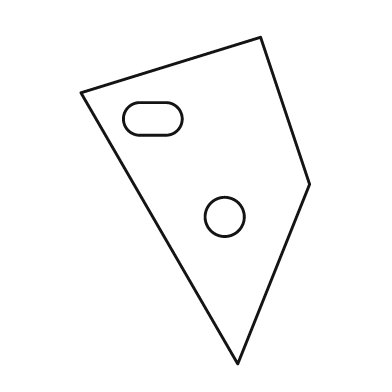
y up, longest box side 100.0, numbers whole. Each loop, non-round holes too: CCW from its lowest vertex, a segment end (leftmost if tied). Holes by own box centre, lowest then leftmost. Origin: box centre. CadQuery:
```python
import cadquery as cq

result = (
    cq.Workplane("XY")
    .moveTo(13.0, -50.0)
    .lineTo(35.0, 5.0)
    .lineTo(20.0, 50.0)
    .lineTo(-35.0, 33.0)
    .close()
    .moveTo(9.0, -5.0)
    .circle(6.0)
    .moveTo(-17.0, 20.0)
    .lineTo(-9.0, 20.0)
    .threePointArc((-4.0, 25.0), (-9.0, 30.0))
    .lineTo(-17.0, 30.0)
    .threePointArc((-22.0, 25.0), (-17.0, 20.0))
    .close()
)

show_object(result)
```